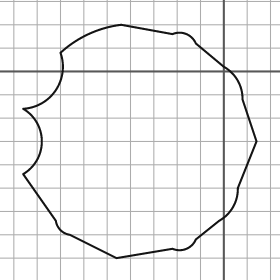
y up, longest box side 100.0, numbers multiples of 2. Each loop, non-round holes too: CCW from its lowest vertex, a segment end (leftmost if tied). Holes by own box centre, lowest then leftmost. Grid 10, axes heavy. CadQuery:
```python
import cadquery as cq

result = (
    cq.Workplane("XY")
    .moveTo(-46.0, -80.0)
    .lineTo(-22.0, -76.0)
    .threePointArc((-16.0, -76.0), (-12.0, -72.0))
    .lineTo(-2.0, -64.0)
    .threePointArc((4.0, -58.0), (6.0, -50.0))
    .lineTo(14.0, -30.0)
    .lineTo(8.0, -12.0)
    .threePointArc((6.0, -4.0), (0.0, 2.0))
    .lineTo(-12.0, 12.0)
    .threePointArc((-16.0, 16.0), (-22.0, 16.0))
    .lineTo(-44.0, 20.0)
    .threePointArc((-58.0, 16.0), (-70.0, 8.0))
    .threePointArc((-72.0, -8.0), (-86.0, -16.0))
    .threePointArc((-78.0, -30.0), (-86.0, -44.0))
    .lineTo(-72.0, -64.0)
    .threePointArc((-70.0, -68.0), (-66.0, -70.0))
    .close()
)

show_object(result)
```